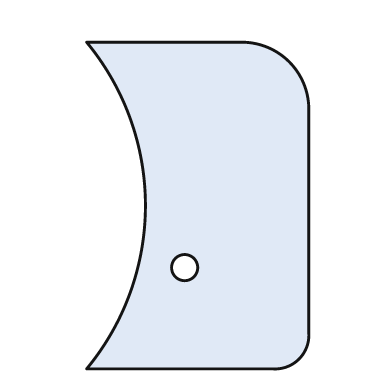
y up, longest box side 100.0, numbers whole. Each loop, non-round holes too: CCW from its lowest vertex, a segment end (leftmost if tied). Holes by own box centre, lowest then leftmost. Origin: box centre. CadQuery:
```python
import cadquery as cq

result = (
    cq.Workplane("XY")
    .moveTo(-34.0, -50.0)
    .lineTo(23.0, -50.0)
    .threePointArc((31.0, -47.0), (34.0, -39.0))
    .lineTo(34.0, 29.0)
    .threePointArc((28.0, 44.0), (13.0, 50.0))
    .lineTo(-34.0, 50.0)
    .threePointArc((-16.0, 0.0), (-34.0, -50.0))
    .close()
    .moveTo(-4.0, -19.0)
    .circle(4.0)
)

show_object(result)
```